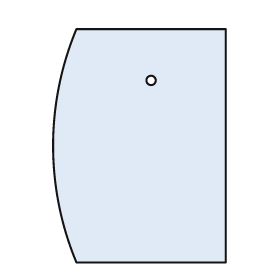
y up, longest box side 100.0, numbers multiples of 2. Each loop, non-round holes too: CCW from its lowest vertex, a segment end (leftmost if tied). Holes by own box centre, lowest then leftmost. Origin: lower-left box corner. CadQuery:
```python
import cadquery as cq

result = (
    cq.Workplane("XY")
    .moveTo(10.0, 0.0)
    .lineTo(74.0, 0.0)
    .lineTo(74.0, 100.0)
    .lineTo(10.0, 100.0)
    .threePointArc((0.0, 50.0), (10.0, 0.0))
    .close()
    .moveTo(42.0, 78.0)
    .circle(2.0)
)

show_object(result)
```